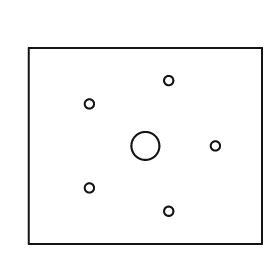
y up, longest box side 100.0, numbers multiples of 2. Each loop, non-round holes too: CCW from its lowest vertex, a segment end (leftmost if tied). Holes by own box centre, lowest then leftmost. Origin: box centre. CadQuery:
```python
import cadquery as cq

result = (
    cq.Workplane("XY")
    .moveTo(-50.0, -42.0)
    .lineTo(50.0, -42.0)
    .lineTo(50.0, 42.0)
    .lineTo(-50.0, 42.0)
    .close()
    .moveTo(10.0, -28.0)
    .circle(2.0)
    .moveTo(-24.0, -18.0)
    .circle(2.0)
    .moveTo(0.0, 0.0)
    .circle(6.0)
    .moveTo(30.0, 0.0)
    .circle(2.0)
    .moveTo(-24.0, 18.0)
    .circle(2.0)
    .moveTo(10.0, 28.0)
    .circle(2.0)
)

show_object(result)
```